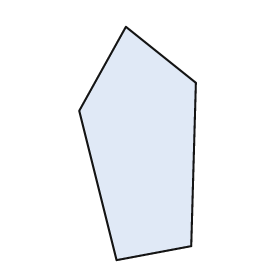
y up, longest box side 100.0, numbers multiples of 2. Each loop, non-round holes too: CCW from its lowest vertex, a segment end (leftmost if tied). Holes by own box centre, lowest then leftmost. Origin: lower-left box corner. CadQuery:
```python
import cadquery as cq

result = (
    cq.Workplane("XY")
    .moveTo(16.0, 0.0)
    .lineTo(48.0, 6.0)
    .lineTo(50.0, 76.0)
    .lineTo(20.0, 100.0)
    .lineTo(0.0, 64.0)
    .close()
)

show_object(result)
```